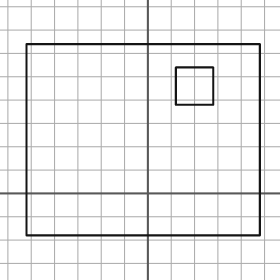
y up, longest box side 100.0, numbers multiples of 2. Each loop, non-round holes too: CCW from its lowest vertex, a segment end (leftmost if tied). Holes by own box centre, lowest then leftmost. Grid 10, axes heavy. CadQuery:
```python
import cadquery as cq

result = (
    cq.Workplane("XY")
    .moveTo(-52.0, -18.0)
    .lineTo(48.0, -18.0)
    .lineTo(48.0, 64.0)
    .lineTo(-52.0, 64.0)
    .close()
    .moveTo(12.0, 38.0)
    .lineTo(28.0, 38.0)
    .lineTo(28.0, 54.0)
    .lineTo(12.0, 54.0)
    .close()
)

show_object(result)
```